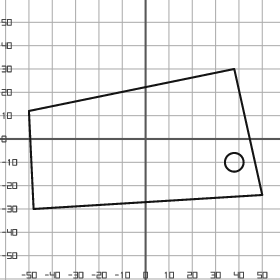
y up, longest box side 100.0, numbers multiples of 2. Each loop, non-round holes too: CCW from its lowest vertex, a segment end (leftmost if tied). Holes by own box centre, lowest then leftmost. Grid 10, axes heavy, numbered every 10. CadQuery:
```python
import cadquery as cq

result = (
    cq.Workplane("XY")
    .moveTo(-48.0, -30.0)
    .lineTo(50.0, -24.0)
    .lineTo(38.0, 30.0)
    .lineTo(-50.0, 12.0)
    .close()
    .moveTo(38.0, -10.0)
    .circle(4.0)
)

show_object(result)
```